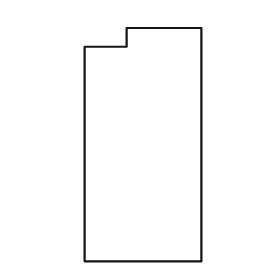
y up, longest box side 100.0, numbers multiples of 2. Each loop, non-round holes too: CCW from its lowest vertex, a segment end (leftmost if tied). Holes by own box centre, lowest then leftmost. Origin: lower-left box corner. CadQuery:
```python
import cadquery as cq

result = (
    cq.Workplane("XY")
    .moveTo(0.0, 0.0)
    .lineTo(50.0, 0.0)
    .lineTo(50.0, 100.0)
    .lineTo(18.0, 100.0)
    .lineTo(18.0, 92.0)
    .lineTo(0.0, 92.0)
    .close()
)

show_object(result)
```